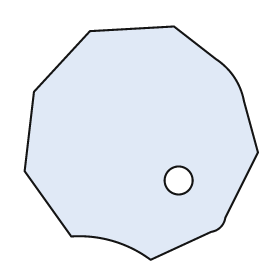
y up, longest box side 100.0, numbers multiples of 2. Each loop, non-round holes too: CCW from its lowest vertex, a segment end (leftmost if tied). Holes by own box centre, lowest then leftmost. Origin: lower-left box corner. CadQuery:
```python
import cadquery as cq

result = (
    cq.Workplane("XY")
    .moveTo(54.0, 0.0)
    .lineTo(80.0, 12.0)
    .threePointArc((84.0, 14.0), (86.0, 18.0))
    .lineTo(100.0, 46.0)
    .lineTo(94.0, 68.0)
    .threePointArc((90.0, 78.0), (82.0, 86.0))
    .lineTo(64.0, 100.0)
    .lineTo(28.0, 98.0)
    .lineTo(4.0, 72.0)
    .lineTo(0.0, 38.0)
    .lineTo(20.0, 10.0)
    .threePointArc((38.0, 8.0), (54.0, 0.0))
    .close()
    .moveTo(66.0, 34.0)
    .circle(6.0)
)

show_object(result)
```